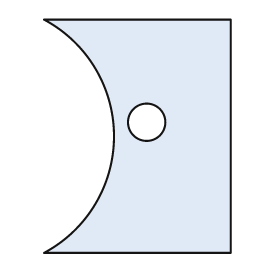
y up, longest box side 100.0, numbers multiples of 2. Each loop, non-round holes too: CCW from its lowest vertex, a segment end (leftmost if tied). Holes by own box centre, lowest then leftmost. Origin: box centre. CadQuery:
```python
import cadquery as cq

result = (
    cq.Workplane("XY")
    .moveTo(-40.0, -50.0)
    .lineTo(40.0, -50.0)
    .lineTo(40.0, 50.0)
    .lineTo(-40.0, 50.0)
    .threePointArc((-10.0, 0.0), (-40.0, -50.0))
    .close()
    .moveTo(4.0, 6.0)
    .circle(8.0)
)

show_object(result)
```